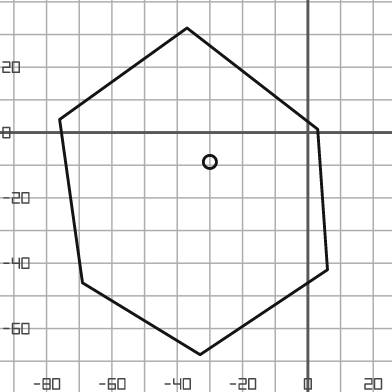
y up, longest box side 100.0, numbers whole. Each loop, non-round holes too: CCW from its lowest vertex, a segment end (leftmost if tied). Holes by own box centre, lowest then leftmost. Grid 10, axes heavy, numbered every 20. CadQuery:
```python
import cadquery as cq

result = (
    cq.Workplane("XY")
    .moveTo(-33.0, -68.0)
    .lineTo(6.0, -42.0)
    .lineTo(3.0, 1.0)
    .lineTo(-37.0, 32.0)
    .lineTo(-76.0, 4.0)
    .lineTo(-69.0, -46.0)
    .close()
    .moveTo(-30.0, -9.0)
    .circle(2.0)
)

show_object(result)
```